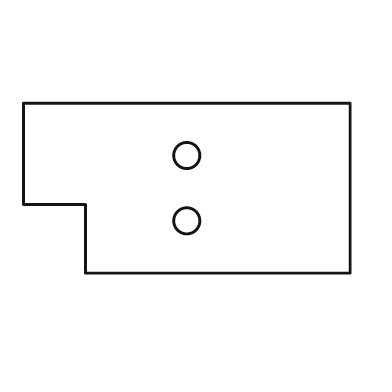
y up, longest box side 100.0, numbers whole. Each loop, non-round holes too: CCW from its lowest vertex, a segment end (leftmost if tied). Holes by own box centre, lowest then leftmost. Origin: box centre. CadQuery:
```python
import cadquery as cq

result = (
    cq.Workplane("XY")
    .moveTo(-31.0, -26.0)
    .lineTo(50.0, -26.0)
    .lineTo(50.0, 26.0)
    .lineTo(-50.0, 26.0)
    .lineTo(-50.0, -5.0)
    .lineTo(-31.0, -5.0)
    .close()
    .moveTo(0.0, -10.0)
    .circle(4.0)
    .moveTo(0.0, 10.0)
    .circle(4.0)
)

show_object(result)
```